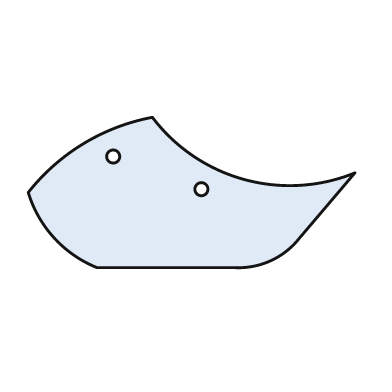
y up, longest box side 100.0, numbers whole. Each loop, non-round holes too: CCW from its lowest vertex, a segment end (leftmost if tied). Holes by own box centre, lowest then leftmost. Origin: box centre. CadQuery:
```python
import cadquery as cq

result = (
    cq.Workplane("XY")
    .moveTo(-29.0, -23.0)
    .lineTo(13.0, -23.0)
    .threePointArc((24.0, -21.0), (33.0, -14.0))
    .lineTo(50.0, 6.0)
    .threePointArc((16.0, 4.0), (-12.0, 23.0))
    .threePointArc((-33.0, 15.0), (-50.0, 0.0))
    .threePointArc((-42.0, -14.0), (-29.0, -23.0))
    .close()
    .moveTo(3.0, 1.0)
    .circle(2.0)
    .moveTo(-24.0, 11.0)
    .circle(2.0)
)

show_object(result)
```